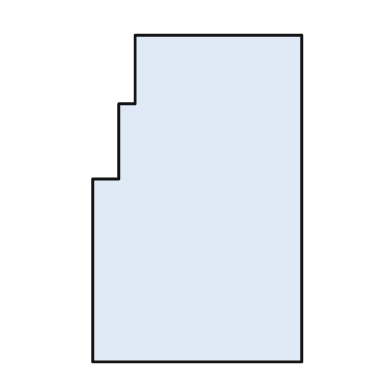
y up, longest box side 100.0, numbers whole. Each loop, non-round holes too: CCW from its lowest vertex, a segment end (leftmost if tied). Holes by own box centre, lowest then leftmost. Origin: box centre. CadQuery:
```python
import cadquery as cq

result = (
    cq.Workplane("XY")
    .moveTo(-32.0, -50.0)
    .lineTo(32.0, -50.0)
    .lineTo(32.0, 50.0)
    .lineTo(-19.0, 50.0)
    .lineTo(-19.0, 29.0)
    .lineTo(-24.0, 29.0)
    .lineTo(-24.0, 6.0)
    .lineTo(-32.0, 6.0)
    .close()
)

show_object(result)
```